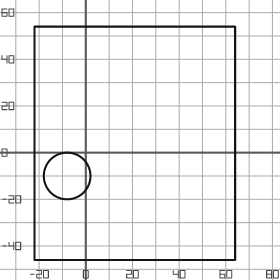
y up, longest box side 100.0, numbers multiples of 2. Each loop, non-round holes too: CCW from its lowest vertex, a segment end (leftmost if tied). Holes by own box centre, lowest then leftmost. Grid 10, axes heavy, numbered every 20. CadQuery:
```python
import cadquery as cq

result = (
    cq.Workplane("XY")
    .moveTo(-22.0, -46.0)
    .lineTo(64.0, -46.0)
    .lineTo(64.0, 54.0)
    .lineTo(-22.0, 54.0)
    .close()
    .moveTo(-8.0, -10.0)
    .circle(10.0)
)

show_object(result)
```